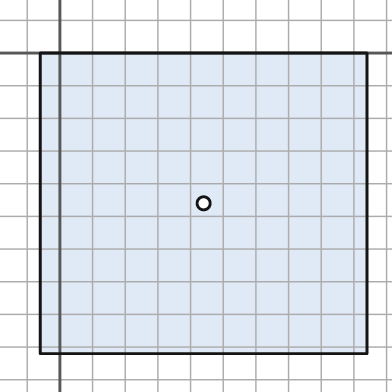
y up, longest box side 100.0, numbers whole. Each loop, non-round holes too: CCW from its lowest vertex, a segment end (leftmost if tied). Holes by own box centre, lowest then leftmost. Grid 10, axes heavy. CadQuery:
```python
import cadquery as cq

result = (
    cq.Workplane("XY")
    .moveTo(-6.0, -92.0)
    .lineTo(94.0, -92.0)
    .lineTo(94.0, 0.0)
    .lineTo(-6.0, 0.0)
    .close()
    .moveTo(44.0, -46.0)
    .circle(2.0)
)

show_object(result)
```